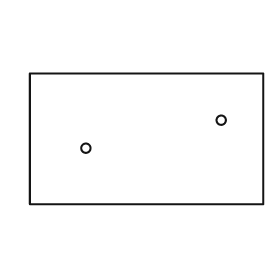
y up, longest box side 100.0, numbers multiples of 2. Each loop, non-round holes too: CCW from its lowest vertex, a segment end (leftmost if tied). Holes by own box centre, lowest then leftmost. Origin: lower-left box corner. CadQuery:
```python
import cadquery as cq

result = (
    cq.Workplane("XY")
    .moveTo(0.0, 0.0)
    .lineTo(100.0, 0.0)
    .lineTo(100.0, 56.0)
    .lineTo(0.0, 56.0)
    .close()
    .moveTo(24.0, 24.0)
    .circle(2.0)
    .moveTo(82.0, 36.0)
    .circle(2.0)
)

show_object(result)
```